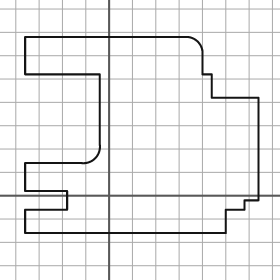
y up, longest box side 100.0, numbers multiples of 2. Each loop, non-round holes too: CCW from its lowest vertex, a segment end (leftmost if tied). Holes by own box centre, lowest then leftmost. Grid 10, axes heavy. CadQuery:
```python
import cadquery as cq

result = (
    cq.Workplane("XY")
    .moveTo(-36.0, -16.0)
    .lineTo(50.0, -16.0)
    .lineTo(50.0, -6.0)
    .lineTo(58.0, -6.0)
    .lineTo(58.0, -2.0)
    .lineTo(64.0, -2.0)
    .lineTo(64.0, 42.0)
    .lineTo(44.0, 42.0)
    .lineTo(44.0, 52.0)
    .lineTo(40.0, 52.0)
    .lineTo(40.0, 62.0)
    .threePointArc((38.0, 66.0), (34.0, 68.0))
    .lineTo(-36.0, 68.0)
    .lineTo(-36.0, 52.0)
    .lineTo(-4.0, 52.0)
    .lineTo(-4.0, 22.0)
    .threePointArc((-6.0, 16.0), (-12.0, 14.0))
    .lineTo(-36.0, 14.0)
    .lineTo(-36.0, 2.0)
    .lineTo(-18.0, 2.0)
    .lineTo(-18.0, -6.0)
    .lineTo(-36.0, -6.0)
    .close()
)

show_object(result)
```